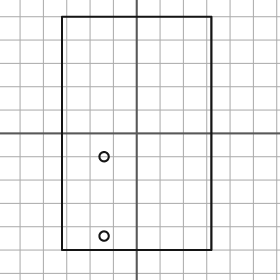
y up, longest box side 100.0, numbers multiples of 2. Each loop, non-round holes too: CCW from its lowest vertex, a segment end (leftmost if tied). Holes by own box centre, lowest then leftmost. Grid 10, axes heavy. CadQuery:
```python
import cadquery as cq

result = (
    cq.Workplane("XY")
    .moveTo(-32.0, -50.0)
    .lineTo(32.0, -50.0)
    .lineTo(32.0, 50.0)
    .lineTo(-32.0, 50.0)
    .close()
    .moveTo(-14.0, -44.0)
    .circle(2.0)
    .moveTo(-14.0, -10.0)
    .circle(2.0)
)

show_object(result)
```